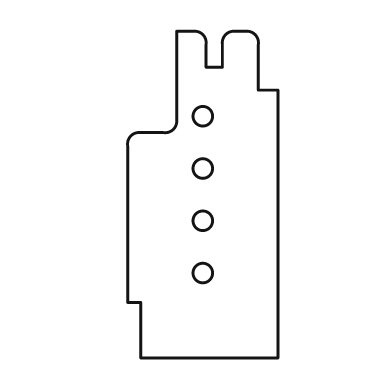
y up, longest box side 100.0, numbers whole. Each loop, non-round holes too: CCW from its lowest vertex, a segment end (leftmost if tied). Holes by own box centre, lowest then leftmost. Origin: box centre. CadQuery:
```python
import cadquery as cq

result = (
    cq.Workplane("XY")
    .moveTo(-19.0, -50.0)
    .lineTo(23.0, -50.0)
    .lineTo(23.0, 32.0)
    .lineTo(17.0, 32.0)
    .lineTo(17.0, 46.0)
    .threePointArc((16.0, 49.0), (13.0, 50.0))
    .lineTo(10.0, 50.0)
    .threePointArc((7.0, 49.0), (6.0, 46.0))
    .lineTo(6.0, 39.0)
    .lineTo(1.0, 39.0)
    .lineTo(1.0, 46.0)
    .threePointArc((0.0, 49.0), (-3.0, 50.0))
    .lineTo(-8.0, 50.0)
    .lineTo(-8.0, 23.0)
    .threePointArc((-9.0, 20.0), (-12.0, 19.0))
    .lineTo(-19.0, 19.0)
    .threePointArc((-22.0, 18.0), (-23.0, 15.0))
    .lineTo(-23.0, -33.0)
    .lineTo(-19.0, -33.0)
    .close()
    .moveTo(0.0, -24.0)
    .circle(3.0)
    .moveTo(0.0, -8.0)
    .circle(3.0)
    .moveTo(0.0, 8.0)
    .circle(3.0)
    .moveTo(0.0, 24.0)
    .circle(3.0)
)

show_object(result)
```